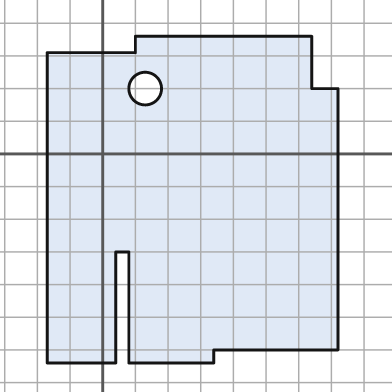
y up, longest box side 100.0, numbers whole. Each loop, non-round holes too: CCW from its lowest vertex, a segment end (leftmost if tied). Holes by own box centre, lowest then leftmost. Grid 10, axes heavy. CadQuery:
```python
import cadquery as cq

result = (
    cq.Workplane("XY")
    .moveTo(-17.0, -64.0)
    .lineTo(4.0, -64.0)
    .lineTo(4.0, -30.0)
    .lineTo(8.0, -30.0)
    .lineTo(8.0, -64.0)
    .lineTo(34.0, -64.0)
    .lineTo(34.0, -60.0)
    .lineTo(72.0, -60.0)
    .lineTo(72.0, 20.0)
    .lineTo(64.0, 20.0)
    .lineTo(64.0, 36.0)
    .lineTo(10.0, 36.0)
    .lineTo(10.0, 31.0)
    .lineTo(-17.0, 31.0)
    .close()
    .moveTo(13.0, 20.0)
    .circle(5.0)
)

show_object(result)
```